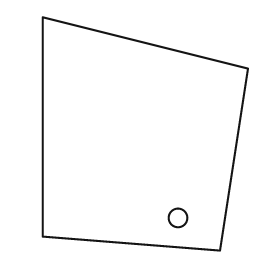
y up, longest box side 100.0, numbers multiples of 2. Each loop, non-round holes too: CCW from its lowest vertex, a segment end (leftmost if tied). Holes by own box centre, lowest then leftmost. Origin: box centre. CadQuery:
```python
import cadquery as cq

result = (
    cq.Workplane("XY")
    .moveTo(32.0, -50.0)
    .lineTo(44.0, 28.0)
    .lineTo(-44.0, 50.0)
    .lineTo(-44.0, -44.0)
    .close()
    .moveTo(14.0, -36.0)
    .circle(4.0)
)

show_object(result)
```